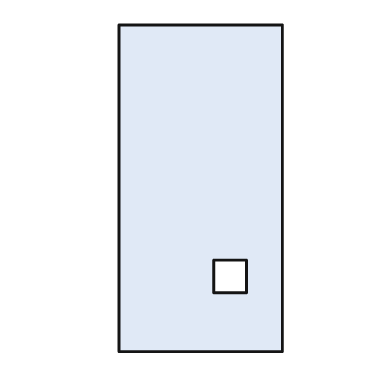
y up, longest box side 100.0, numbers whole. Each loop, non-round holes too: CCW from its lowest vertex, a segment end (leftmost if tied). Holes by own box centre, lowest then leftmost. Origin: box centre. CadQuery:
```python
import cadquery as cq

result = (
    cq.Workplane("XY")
    .moveTo(-25.0, -50.0)
    .lineTo(25.0, -50.0)
    .lineTo(25.0, 50.0)
    .lineTo(-25.0, 50.0)
    .close()
    .moveTo(4.0, -32.0)
    .lineTo(14.0, -32.0)
    .lineTo(14.0, -22.0)
    .lineTo(4.0, -22.0)
    .close()
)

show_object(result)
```